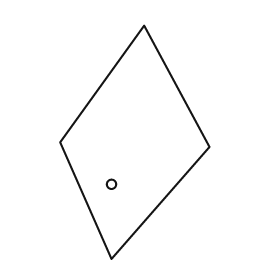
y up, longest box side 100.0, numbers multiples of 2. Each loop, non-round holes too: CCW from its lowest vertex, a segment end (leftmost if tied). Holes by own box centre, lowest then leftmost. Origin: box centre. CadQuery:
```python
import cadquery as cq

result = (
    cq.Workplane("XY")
    .moveTo(-10.0, -50.0)
    .lineTo(32.0, -2.0)
    .lineTo(4.0, 50.0)
    .lineTo(-32.0, 0.0)
    .close()
    .moveTo(-10.0, -18.0)
    .circle(2.0)
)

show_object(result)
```